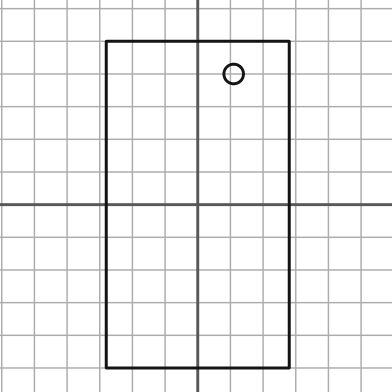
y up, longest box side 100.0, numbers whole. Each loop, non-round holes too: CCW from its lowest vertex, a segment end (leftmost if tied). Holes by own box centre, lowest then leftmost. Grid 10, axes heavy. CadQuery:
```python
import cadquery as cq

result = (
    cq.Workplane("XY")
    .moveTo(-28.0, -50.0)
    .lineTo(28.0, -50.0)
    .lineTo(28.0, 50.0)
    .lineTo(-28.0, 50.0)
    .close()
    .moveTo(11.0, 40.0)
    .circle(3.0)
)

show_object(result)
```